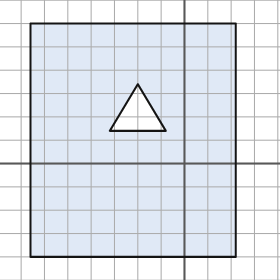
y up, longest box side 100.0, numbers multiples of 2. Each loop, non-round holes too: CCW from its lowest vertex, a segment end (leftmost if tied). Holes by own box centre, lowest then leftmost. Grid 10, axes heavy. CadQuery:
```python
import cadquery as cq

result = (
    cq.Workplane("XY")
    .moveTo(-66.0, -40.0)
    .lineTo(22.0, -40.0)
    .lineTo(22.0, 60.0)
    .lineTo(-66.0, 60.0)
    .close()
    .moveTo(-32.0, 14.0)
    .lineTo(-8.0, 14.0)
    .lineTo(-20.0, 34.0)
    .close()
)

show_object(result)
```